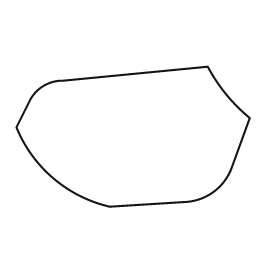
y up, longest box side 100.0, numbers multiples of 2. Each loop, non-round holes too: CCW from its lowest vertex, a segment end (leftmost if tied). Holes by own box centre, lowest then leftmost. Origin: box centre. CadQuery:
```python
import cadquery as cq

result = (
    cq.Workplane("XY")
    .moveTo(-10.0, -30.0)
    .lineTo(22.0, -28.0)
    .threePointArc((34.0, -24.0), (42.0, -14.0))
    .lineTo(50.0, 8.0)
    .threePointArc((40.0, 18.0), (32.0, 30.0))
    .lineTo(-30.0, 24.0)
    .threePointArc((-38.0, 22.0), (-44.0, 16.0))
    .lineTo(-50.0, 4.0)
    .threePointArc((-34.0, -18.0), (-10.0, -30.0))
    .close()
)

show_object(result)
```